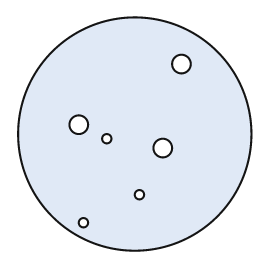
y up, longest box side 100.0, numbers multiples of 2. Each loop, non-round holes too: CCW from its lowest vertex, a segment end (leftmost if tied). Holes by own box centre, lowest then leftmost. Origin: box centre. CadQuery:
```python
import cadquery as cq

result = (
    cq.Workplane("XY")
    .moveTo(0.0, 0.0)
    .circle(50.0)
    .moveTo(-22.0, -38.0)
    .circle(2.0)
    .moveTo(2.0, -26.0)
    .circle(2.0)
    .moveTo(12.0, -6.0)
    .circle(4.0)
    .moveTo(-12.0, -2.0)
    .circle(2.0)
    .moveTo(-24.0, 4.0)
    .circle(4.0)
    .moveTo(20.0, 30.0)
    .circle(4.0)
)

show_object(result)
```